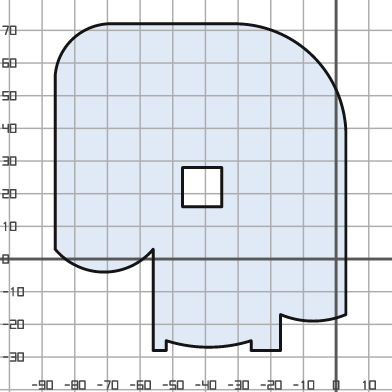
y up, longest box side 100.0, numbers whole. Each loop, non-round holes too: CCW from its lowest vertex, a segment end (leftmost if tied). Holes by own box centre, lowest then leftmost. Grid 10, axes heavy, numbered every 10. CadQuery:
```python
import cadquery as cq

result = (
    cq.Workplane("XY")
    .moveTo(-56.0, -28.0)
    .lineTo(-52.0, -28.0)
    .lineTo(-52.0, -25.0)
    .threePointArc((-39.0, -27.0), (-26.0, -25.0))
    .lineTo(-26.0, -28.0)
    .lineTo(-17.0, -28.0)
    .lineTo(-17.0, -17.0)
    .threePointArc((-7.0, -19.0), (3.0, -17.0))
    .lineTo(3.0, 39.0)
    .threePointArc((-7.0, 62.0), (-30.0, 72.0))
    .lineTo(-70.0, 72.0)
    .threePointArc((-81.0, 67.0), (-86.0, 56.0))
    .lineTo(-86.0, 3.0)
    .threePointArc((-71.0, -4.0), (-56.0, 3.0))
    .close()
    .moveTo(-47.0, 16.0)
    .lineTo(-35.0, 16.0)
    .lineTo(-35.0, 28.0)
    .lineTo(-47.0, 28.0)
    .close()
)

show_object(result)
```